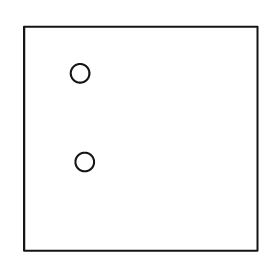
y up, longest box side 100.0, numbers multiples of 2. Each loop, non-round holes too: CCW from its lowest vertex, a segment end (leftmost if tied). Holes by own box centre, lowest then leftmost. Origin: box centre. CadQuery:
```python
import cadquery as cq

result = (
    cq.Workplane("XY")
    .moveTo(-50.0, -48.0)
    .lineTo(50.0, -48.0)
    .lineTo(50.0, 48.0)
    .lineTo(-50.0, 48.0)
    .close()
    .moveTo(-24.0, -10.0)
    .circle(4.0)
    .moveTo(-26.0, 28.0)
    .circle(4.0)
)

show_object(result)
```